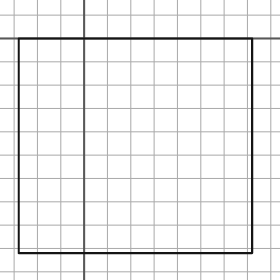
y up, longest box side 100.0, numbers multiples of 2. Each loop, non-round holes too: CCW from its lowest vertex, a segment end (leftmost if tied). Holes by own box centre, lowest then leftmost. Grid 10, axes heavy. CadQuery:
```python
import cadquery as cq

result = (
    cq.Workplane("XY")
    .moveTo(-28.0, -92.0)
    .lineTo(72.0, -92.0)
    .lineTo(72.0, 0.0)
    .lineTo(-28.0, 0.0)
    .close()
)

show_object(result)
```